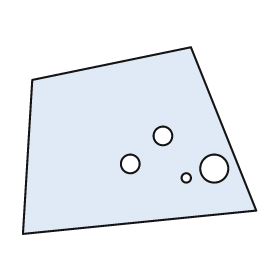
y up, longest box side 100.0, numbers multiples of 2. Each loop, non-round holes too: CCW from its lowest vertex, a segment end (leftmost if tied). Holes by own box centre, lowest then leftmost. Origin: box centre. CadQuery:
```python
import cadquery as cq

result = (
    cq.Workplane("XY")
    .moveTo(-50.0, -40.0)
    .lineTo(50.0, -30.0)
    .lineTo(22.0, 40.0)
    .lineTo(-46.0, 26.0)
    .close()
    .moveTo(20.0, -16.0)
    .circle(2.0)
    .moveTo(32.0, -12.0)
    .circle(6.0)
    .moveTo(-4.0, -10.0)
    .circle(4.0)
    .moveTo(10.0, 2.0)
    .circle(4.0)
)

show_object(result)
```